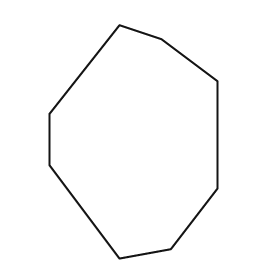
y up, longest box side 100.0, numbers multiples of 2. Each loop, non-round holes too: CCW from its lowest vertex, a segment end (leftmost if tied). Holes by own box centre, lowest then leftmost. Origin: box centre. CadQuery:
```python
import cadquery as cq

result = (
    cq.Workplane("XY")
    .moveTo(-6.0, -50.0)
    .lineTo(16.0, -46.0)
    .lineTo(36.0, -20.0)
    .lineTo(36.0, 26.0)
    .lineTo(12.0, 44.0)
    .lineTo(-6.0, 50.0)
    .lineTo(-36.0, 12.0)
    .lineTo(-36.0, -10.0)
    .close()
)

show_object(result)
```